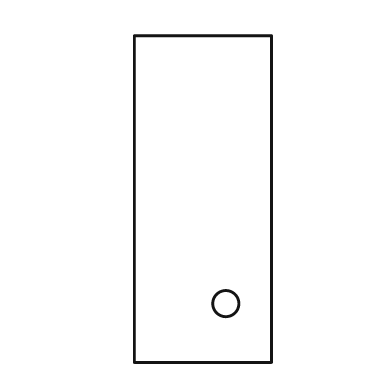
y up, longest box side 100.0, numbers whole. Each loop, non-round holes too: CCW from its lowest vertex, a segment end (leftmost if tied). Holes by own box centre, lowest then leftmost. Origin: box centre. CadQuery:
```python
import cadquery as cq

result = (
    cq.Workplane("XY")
    .moveTo(-21.0, -50.0)
    .lineTo(21.0, -50.0)
    .lineTo(21.0, 50.0)
    .lineTo(-21.0, 50.0)
    .close()
    .moveTo(7.0, -32.0)
    .circle(4.0)
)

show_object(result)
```